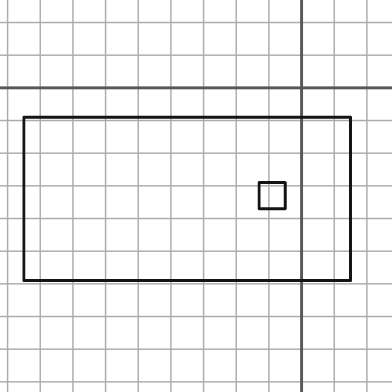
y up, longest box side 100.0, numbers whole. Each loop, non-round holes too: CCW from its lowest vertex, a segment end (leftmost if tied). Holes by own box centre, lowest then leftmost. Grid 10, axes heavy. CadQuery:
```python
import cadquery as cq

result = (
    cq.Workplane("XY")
    .moveTo(-85.0, -59.0)
    .lineTo(15.0, -59.0)
    .lineTo(15.0, -9.0)
    .lineTo(-85.0, -9.0)
    .close()
    .moveTo(-13.0, -37.0)
    .lineTo(-5.0, -37.0)
    .lineTo(-5.0, -29.0)
    .lineTo(-13.0, -29.0)
    .close()
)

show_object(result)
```